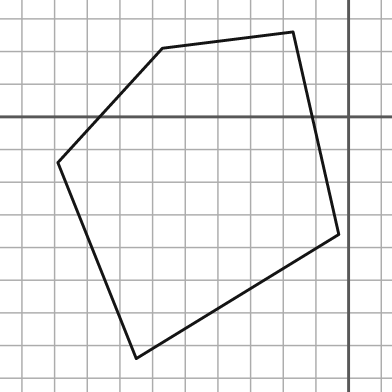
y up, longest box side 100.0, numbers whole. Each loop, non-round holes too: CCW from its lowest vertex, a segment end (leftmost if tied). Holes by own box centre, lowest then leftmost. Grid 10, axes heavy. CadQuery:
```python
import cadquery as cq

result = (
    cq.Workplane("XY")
    .moveTo(-65.0, -74.0)
    .lineTo(-3.0, -36.0)
    .lineTo(-17.0, 26.0)
    .lineTo(-57.0, 21.0)
    .lineTo(-89.0, -14.0)
    .close()
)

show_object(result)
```